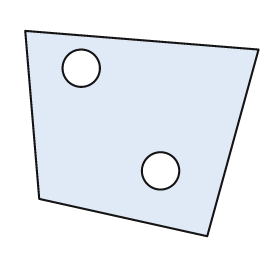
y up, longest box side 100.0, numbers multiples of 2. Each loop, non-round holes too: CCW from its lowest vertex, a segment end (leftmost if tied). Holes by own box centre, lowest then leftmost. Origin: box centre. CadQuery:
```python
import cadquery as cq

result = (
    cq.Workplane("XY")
    .moveTo(28.0, -44.0)
    .lineTo(50.0, 36.0)
    .lineTo(-50.0, 44.0)
    .lineTo(-44.0, -28.0)
    .close()
    .moveTo(8.0, -16.0)
    .circle(8.0)
    .moveTo(-26.0, 28.0)
    .circle(8.0)
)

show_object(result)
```